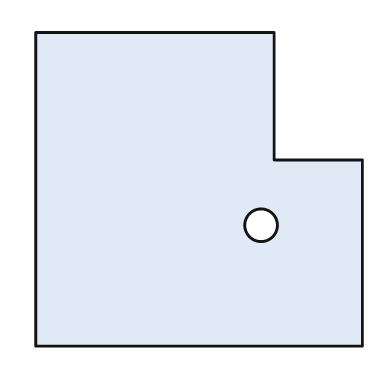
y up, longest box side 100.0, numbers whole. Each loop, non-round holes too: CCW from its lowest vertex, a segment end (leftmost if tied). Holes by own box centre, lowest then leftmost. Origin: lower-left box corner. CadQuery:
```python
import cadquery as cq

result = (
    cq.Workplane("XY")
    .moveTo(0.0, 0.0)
    .lineTo(100.0, 0.0)
    .lineTo(100.0, 57.0)
    .lineTo(73.0, 57.0)
    .lineTo(73.0, 96.0)
    .lineTo(0.0, 96.0)
    .close()
    .moveTo(69.0, 37.0)
    .circle(5.0)
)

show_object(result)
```